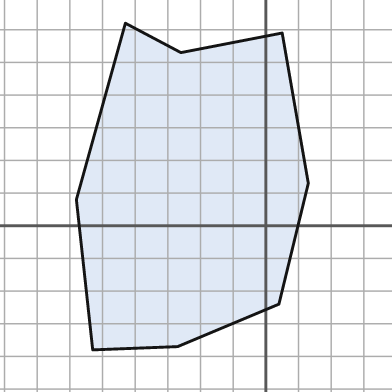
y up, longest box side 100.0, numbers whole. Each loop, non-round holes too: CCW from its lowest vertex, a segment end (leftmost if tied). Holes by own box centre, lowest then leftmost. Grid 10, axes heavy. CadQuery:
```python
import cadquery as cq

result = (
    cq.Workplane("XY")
    .moveTo(-53.0, -38.0)
    .lineTo(-27.0, -37.0)
    .lineTo(4.0, -24.0)
    .lineTo(13.0, 13.0)
    .lineTo(5.0, 59.0)
    .lineTo(-26.0, 53.0)
    .lineTo(-43.0, 62.0)
    .lineTo(-58.0, 8.0)
    .close()
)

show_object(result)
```